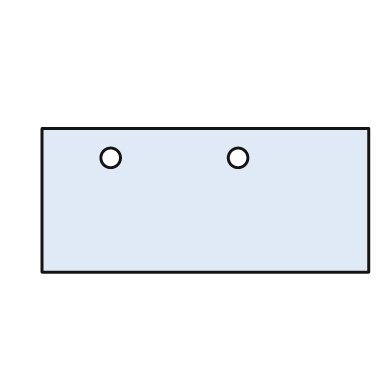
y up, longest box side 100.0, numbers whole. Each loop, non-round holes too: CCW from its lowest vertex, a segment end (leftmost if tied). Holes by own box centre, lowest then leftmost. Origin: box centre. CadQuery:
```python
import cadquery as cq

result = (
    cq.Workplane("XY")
    .moveTo(-50.0, -22.0)
    .lineTo(50.0, -22.0)
    .lineTo(50.0, 22.0)
    .lineTo(-50.0, 22.0)
    .close()
    .moveTo(-29.0, 13.0)
    .circle(3.0)
    .moveTo(10.0, 13.0)
    .circle(3.0)
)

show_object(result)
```